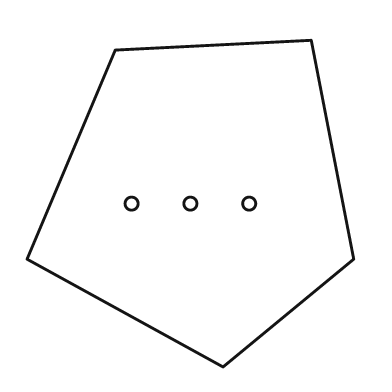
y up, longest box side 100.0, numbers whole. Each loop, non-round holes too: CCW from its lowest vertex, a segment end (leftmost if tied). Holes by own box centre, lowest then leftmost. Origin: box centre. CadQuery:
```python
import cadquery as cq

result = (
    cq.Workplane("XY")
    .moveTo(10.0, -50.0)
    .lineTo(50.0, -17.0)
    .lineTo(37.0, 50.0)
    .lineTo(-23.0, 47.0)
    .lineTo(-50.0, -17.0)
    .close()
    .moveTo(-18.0, 0.0)
    .circle(2.0)
    .moveTo(0.0, 0.0)
    .circle(2.0)
    .moveTo(18.0, 0.0)
    .circle(2.0)
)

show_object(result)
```